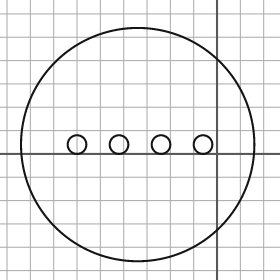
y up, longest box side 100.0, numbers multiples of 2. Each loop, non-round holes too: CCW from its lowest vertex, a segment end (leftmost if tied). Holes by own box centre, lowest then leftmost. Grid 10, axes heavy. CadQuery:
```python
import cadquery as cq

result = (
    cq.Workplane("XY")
    .moveTo(-34.0, 4.0)
    .circle(50.0)
    .moveTo(-60.0, 4.0)
    .circle(4.0)
    .moveTo(-42.0, 4.0)
    .circle(4.0)
    .moveTo(-24.0, 4.0)
    .circle(4.0)
    .moveTo(-6.0, 4.0)
    .circle(4.0)
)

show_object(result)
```